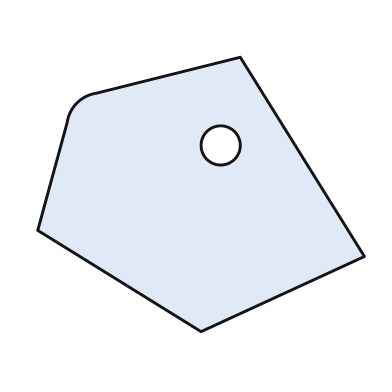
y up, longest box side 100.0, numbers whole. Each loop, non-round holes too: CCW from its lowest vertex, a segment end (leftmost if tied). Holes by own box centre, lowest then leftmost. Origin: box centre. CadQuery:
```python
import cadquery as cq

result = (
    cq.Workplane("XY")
    .moveTo(0.0, -42.0)
    .lineTo(50.0, -19.0)
    .lineTo(12.0, 42.0)
    .lineTo(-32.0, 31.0)
    .threePointArc((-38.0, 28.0), (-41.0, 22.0))
    .lineTo(-50.0, -11.0)
    .close()
    .moveTo(6.0, 15.0)
    .circle(6.0)
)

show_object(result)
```